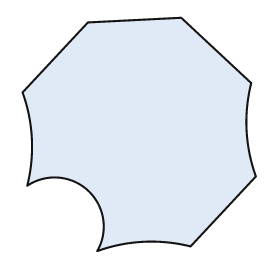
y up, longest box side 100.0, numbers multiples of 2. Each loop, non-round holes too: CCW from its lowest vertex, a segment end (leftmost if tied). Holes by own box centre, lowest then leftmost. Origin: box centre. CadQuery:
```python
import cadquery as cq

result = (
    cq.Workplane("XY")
    .moveTo(-18.0, -50.0)
    .threePointArc((2.0, -46.0), (22.0, -48.0))
    .lineTo(50.0, -18.0)
    .threePointArc((46.0, 2.0), (48.0, 22.0))
    .lineTo(18.0, 50.0)
    .lineTo(-22.0, 48.0)
    .lineTo(-50.0, 18.0)
    .threePointArc((-46.0, -2.0), (-48.0, -22.0))
    .threePointArc((-22.0, -24.0), (-18.0, -50.0))
    .close()
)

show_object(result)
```